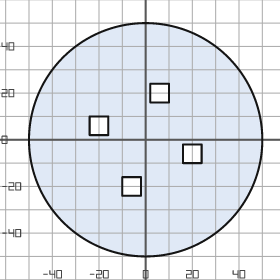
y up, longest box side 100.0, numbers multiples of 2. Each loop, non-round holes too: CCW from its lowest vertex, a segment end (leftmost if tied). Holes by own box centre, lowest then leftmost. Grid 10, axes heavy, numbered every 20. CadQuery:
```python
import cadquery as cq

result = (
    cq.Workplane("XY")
    .moveTo(0.0, 0.0)
    .circle(50.0)
    .moveTo(-10.0, -24.0)
    .lineTo(-2.0, -24.0)
    .lineTo(-2.0, -16.0)
    .lineTo(-10.0, -16.0)
    .close()
    .moveTo(16.0, -10.0)
    .lineTo(24.0, -10.0)
    .lineTo(24.0, -2.0)
    .lineTo(16.0, -2.0)
    .close()
    .moveTo(-24.0, 2.0)
    .lineTo(-16.0, 2.0)
    .lineTo(-16.0, 10.0)
    .lineTo(-24.0, 10.0)
    .close()
    .moveTo(2.0, 16.0)
    .lineTo(10.0, 16.0)
    .lineTo(10.0, 24.0)
    .lineTo(2.0, 24.0)
    .close()
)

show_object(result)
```